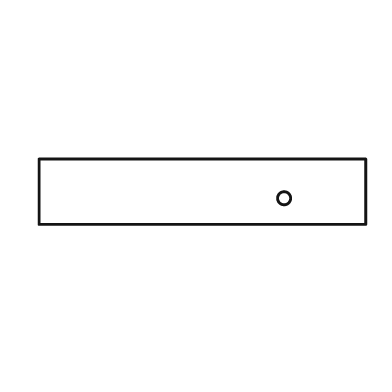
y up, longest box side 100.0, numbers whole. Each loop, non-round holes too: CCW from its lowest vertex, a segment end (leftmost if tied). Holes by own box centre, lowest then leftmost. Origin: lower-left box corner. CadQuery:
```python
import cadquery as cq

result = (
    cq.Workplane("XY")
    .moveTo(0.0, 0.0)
    .lineTo(100.0, 0.0)
    .lineTo(100.0, 20.0)
    .lineTo(0.0, 20.0)
    .close()
    .moveTo(75.0, 8.0)
    .circle(2.0)
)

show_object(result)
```